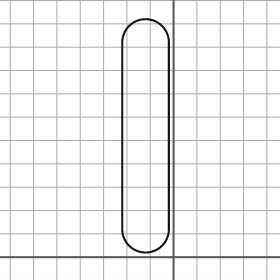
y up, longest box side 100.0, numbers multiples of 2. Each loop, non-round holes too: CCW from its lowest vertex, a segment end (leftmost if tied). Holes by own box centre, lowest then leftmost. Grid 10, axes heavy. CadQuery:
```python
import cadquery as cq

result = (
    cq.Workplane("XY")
    .moveTo(-22.0, 12.0)
    .threePointArc((-12.0, 2.0), (-2.0, 12.0))
    .lineTo(-2.0, 92.0)
    .threePointArc((-12.0, 102.0), (-22.0, 92.0))
    .close()
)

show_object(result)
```